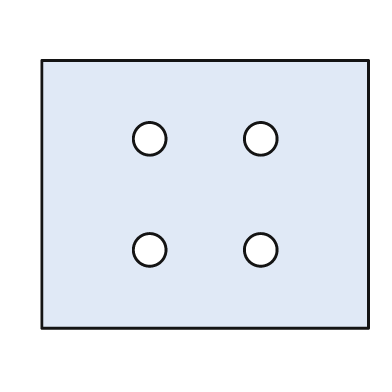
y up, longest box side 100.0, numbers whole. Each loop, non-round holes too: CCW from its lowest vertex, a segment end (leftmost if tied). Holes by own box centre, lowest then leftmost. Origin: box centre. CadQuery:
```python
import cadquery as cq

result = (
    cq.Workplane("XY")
    .moveTo(-50.0, -41.0)
    .lineTo(50.0, -41.0)
    .lineTo(50.0, 41.0)
    .lineTo(-50.0, 41.0)
    .close()
    .moveTo(-17.0, -17.0)
    .circle(5.0)
    .moveTo(17.0, -17.0)
    .circle(5.0)
    .moveTo(-17.0, 17.0)
    .circle(5.0)
    .moveTo(17.0, 17.0)
    .circle(5.0)
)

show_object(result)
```